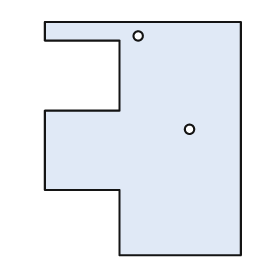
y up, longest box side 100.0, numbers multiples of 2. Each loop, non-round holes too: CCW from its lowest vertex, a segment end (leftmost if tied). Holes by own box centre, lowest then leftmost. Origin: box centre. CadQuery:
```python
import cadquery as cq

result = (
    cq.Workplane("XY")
    .moveTo(-10.0, -50.0)
    .lineTo(42.0, -50.0)
    .lineTo(42.0, 50.0)
    .lineTo(-42.0, 50.0)
    .lineTo(-42.0, 42.0)
    .lineTo(-10.0, 42.0)
    .lineTo(-10.0, 12.0)
    .lineTo(-42.0, 12.0)
    .lineTo(-42.0, -22.0)
    .lineTo(-10.0, -22.0)
    .close()
    .moveTo(20.0, 4.0)
    .circle(2.0)
    .moveTo(-2.0, 44.0)
    .circle(2.0)
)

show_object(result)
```